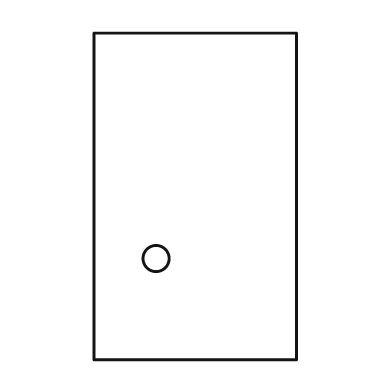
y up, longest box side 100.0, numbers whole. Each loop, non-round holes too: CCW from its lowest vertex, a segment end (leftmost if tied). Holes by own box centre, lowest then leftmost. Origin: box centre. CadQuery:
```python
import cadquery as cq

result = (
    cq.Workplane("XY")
    .moveTo(-31.0, -50.0)
    .lineTo(31.0, -50.0)
    .lineTo(31.0, 50.0)
    .lineTo(-31.0, 50.0)
    .close()
    .moveTo(-12.0, -19.0)
    .circle(4.0)
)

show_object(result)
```